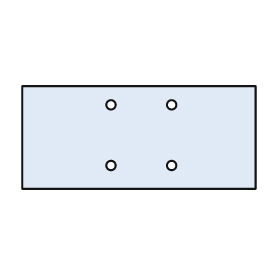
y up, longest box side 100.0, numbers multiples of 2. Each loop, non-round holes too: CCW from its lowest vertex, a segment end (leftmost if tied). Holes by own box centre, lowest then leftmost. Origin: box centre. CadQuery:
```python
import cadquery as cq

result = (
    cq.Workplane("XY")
    .moveTo(-50.0, -22.0)
    .lineTo(50.0, -22.0)
    .lineTo(50.0, 22.0)
    .lineTo(-50.0, 22.0)
    .close()
    .moveTo(-12.0, -12.0)
    .circle(2.0)
    .moveTo(14.0, -12.0)
    .circle(2.0)
    .moveTo(-12.0, 14.0)
    .circle(2.0)
    .moveTo(14.0, 14.0)
    .circle(2.0)
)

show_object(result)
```